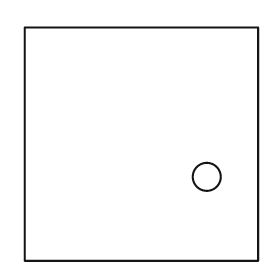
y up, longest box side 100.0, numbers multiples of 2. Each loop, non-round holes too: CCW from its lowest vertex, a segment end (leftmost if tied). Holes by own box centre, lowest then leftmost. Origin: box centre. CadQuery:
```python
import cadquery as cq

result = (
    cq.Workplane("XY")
    .moveTo(-50.0, -50.0)
    .lineTo(50.0, -50.0)
    .lineTo(50.0, 50.0)
    .lineTo(-50.0, 50.0)
    .close()
    .moveTo(28.0, -14.0)
    .circle(6.0)
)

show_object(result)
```